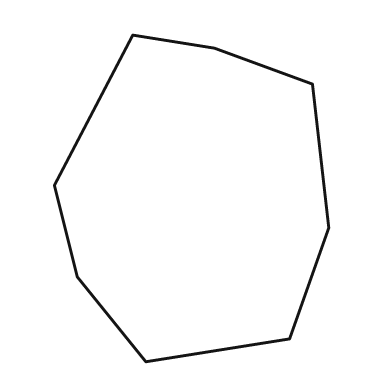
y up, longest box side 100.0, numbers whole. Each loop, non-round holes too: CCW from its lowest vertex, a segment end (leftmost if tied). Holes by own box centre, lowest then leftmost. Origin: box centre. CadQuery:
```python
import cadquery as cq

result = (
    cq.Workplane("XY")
    .moveTo(-14.0, -50.0)
    .lineTo(30.0, -43.0)
    .lineTo(42.0, -9.0)
    .lineTo(37.0, 35.0)
    .lineTo(7.0, 46.0)
    .lineTo(-18.0, 50.0)
    .lineTo(-42.0, 4.0)
    .lineTo(-35.0, -24.0)
    .close()
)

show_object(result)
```